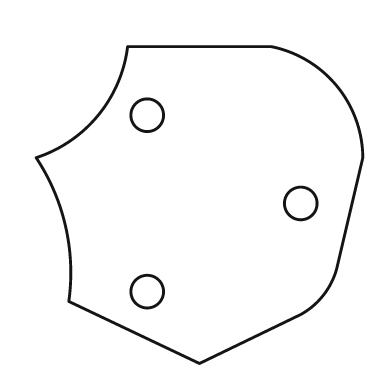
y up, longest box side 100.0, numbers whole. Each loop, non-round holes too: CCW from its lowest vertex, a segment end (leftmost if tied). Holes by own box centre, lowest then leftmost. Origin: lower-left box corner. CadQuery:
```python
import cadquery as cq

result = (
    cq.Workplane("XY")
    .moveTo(50.0, 0.0)
    .lineTo(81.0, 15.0)
    .threePointArc((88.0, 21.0), (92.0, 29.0))
    .lineTo(100.0, 63.0)
    .threePointArc((92.0, 85.0), (72.0, 97.0))
    .lineTo(28.0, 97.0)
    .threePointArc((19.0, 76.0), (0.0, 63.0))
    .threePointArc((9.0, 42.0), (10.0, 19.0))
    .close()
    .moveTo(34.0, 22.0)
    .circle(5.0)
    .moveTo(81.0, 49.0)
    .circle(5.0)
    .moveTo(34.0, 76.0)
    .circle(5.0)
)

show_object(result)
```